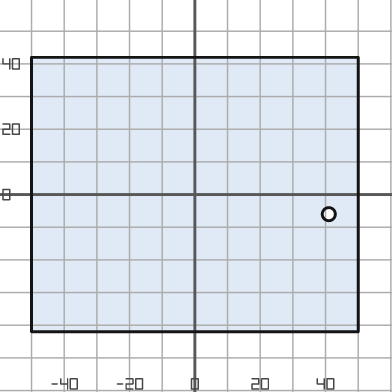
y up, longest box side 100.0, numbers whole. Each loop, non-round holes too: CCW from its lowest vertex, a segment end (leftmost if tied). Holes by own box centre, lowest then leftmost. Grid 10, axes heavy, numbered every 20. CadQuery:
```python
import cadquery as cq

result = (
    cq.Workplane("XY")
    .moveTo(-50.0, -42.0)
    .lineTo(50.0, -42.0)
    .lineTo(50.0, 42.0)
    .lineTo(-50.0, 42.0)
    .close()
    .moveTo(41.0, -6.0)
    .circle(2.0)
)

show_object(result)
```